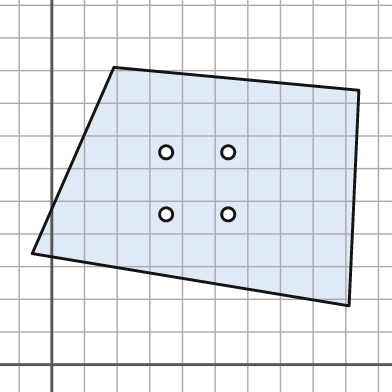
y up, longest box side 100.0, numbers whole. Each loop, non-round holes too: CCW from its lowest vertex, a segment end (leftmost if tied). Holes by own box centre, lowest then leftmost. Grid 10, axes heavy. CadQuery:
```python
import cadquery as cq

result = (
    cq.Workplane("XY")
    .moveTo(91.0, 18.0)
    .lineTo(94.0, 84.0)
    .lineTo(19.0, 91.0)
    .lineTo(-6.0, 34.0)
    .close()
    .moveTo(35.0, 46.0)
    .circle(2.0)
    .moveTo(54.0, 46.0)
    .circle(2.0)
    .moveTo(35.0, 65.0)
    .circle(2.0)
    .moveTo(54.0, 65.0)
    .circle(2.0)
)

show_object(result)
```